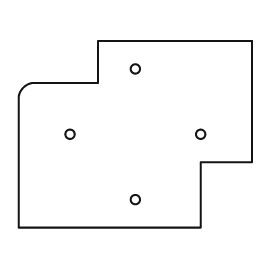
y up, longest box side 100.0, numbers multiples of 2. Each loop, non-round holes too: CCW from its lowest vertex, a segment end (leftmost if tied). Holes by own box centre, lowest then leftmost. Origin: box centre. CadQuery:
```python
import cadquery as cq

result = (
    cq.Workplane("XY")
    .moveTo(-50.0, -40.0)
    .lineTo(28.0, -40.0)
    .lineTo(28.0, -12.0)
    .lineTo(50.0, -12.0)
    .lineTo(50.0, 40.0)
    .lineTo(-16.0, 40.0)
    .lineTo(-16.0, 22.0)
    .lineTo(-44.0, 22.0)
    .threePointArc((-48.0, 20.0), (-50.0, 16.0))
    .close()
    .moveTo(0.0, -28.0)
    .circle(2.0)
    .moveTo(-28.0, 0.0)
    .circle(2.0)
    .moveTo(28.0, 0.0)
    .circle(2.0)
    .moveTo(0.0, 28.0)
    .circle(2.0)
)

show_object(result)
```